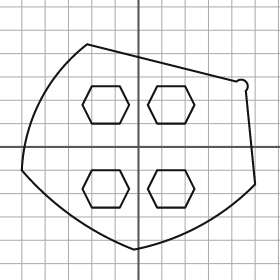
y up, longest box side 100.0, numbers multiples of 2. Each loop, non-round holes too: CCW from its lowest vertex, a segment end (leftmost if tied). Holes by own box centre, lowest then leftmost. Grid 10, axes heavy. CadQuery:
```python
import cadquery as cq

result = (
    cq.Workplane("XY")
    .moveTo(-2.0, -44.0)
    .threePointArc((26.0, -34.0), (50.0, -16.0))
    .lineTo(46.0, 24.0)
    .threePointArc((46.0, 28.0), (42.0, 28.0))
    .lineTo(-22.0, 44.0)
    .threePointArc((-42.0, 20.0), (-50.0, -10.0))
    .threePointArc((-28.0, -30.0), (-2.0, -44.0))
    .close()
    .moveTo(-20.0, -26.0)
    .lineTo(-8.0, -26.0)
    .lineTo(-4.0, -18.0)
    .lineTo(-8.0, -10.0)
    .lineTo(-20.0, -10.0)
    .lineTo(-24.0, -18.0)
    .close()
    .moveTo(8.0, -26.0)
    .lineTo(20.0, -26.0)
    .lineTo(24.0, -18.0)
    .lineTo(20.0, -10.0)
    .lineTo(8.0, -10.0)
    .lineTo(4.0, -18.0)
    .close()
    .moveTo(-20.0, 10.0)
    .lineTo(-8.0, 10.0)
    .lineTo(-4.0, 18.0)
    .lineTo(-8.0, 26.0)
    .lineTo(-20.0, 26.0)
    .lineTo(-24.0, 18.0)
    .close()
    .moveTo(8.0, 10.0)
    .lineTo(20.0, 10.0)
    .lineTo(24.0, 18.0)
    .lineTo(20.0, 26.0)
    .lineTo(8.0, 26.0)
    .lineTo(4.0, 18.0)
    .close()
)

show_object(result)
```